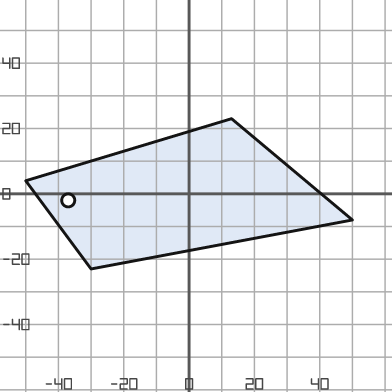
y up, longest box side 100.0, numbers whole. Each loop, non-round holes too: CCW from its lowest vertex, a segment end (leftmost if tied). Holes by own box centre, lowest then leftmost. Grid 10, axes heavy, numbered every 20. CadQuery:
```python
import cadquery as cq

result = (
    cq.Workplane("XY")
    .moveTo(-30.0, -23.0)
    .lineTo(50.0, -8.0)
    .lineTo(13.0, 23.0)
    .lineTo(-50.0, 4.0)
    .close()
    .moveTo(-37.0, -2.0)
    .circle(2.0)
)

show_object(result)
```